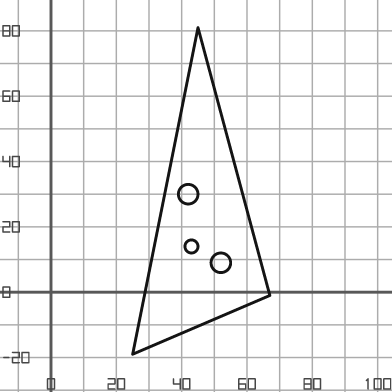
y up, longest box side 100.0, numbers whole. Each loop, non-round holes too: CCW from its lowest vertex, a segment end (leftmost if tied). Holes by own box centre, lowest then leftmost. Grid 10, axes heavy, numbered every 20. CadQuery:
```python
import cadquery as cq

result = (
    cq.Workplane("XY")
    .moveTo(25.0, -19.0)
    .lineTo(67.0, -1.0)
    .lineTo(45.0, 81.0)
    .close()
    .moveTo(52.0, 9.0)
    .circle(3.0)
    .moveTo(43.0, 14.0)
    .circle(2.0)
    .moveTo(42.0, 30.0)
    .circle(3.0)
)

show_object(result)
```